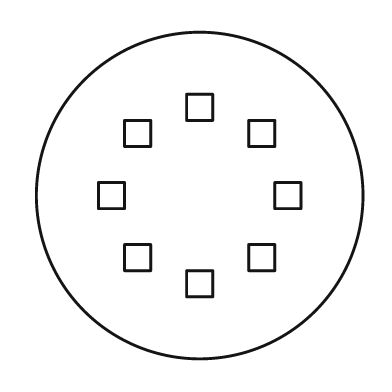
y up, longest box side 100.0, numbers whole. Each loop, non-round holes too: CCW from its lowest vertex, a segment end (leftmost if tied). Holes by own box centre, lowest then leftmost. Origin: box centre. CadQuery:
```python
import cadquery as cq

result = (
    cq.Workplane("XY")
    .moveTo(0.0, 0.0)
    .circle(50.0)
    .moveTo(-4.0, -31.0)
    .lineTo(4.0, -31.0)
    .lineTo(4.0, -23.0)
    .lineTo(-4.0, -23.0)
    .close()
    .moveTo(-23.0, -23.0)
    .lineTo(-15.0, -23.0)
    .lineTo(-15.0, -15.0)
    .lineTo(-23.0, -15.0)
    .close()
    .moveTo(15.0, -23.0)
    .lineTo(23.0, -23.0)
    .lineTo(23.0, -15.0)
    .lineTo(15.0, -15.0)
    .close()
    .moveTo(-31.0, -4.0)
    .lineTo(-23.0, -4.0)
    .lineTo(-23.0, 4.0)
    .lineTo(-31.0, 4.0)
    .close()
    .moveTo(23.0, -4.0)
    .lineTo(31.0, -4.0)
    .lineTo(31.0, 4.0)
    .lineTo(23.0, 4.0)
    .close()
    .moveTo(-23.0, 15.0)
    .lineTo(-15.0, 15.0)
    .lineTo(-15.0, 23.0)
    .lineTo(-23.0, 23.0)
    .close()
    .moveTo(15.0, 15.0)
    .lineTo(23.0, 15.0)
    .lineTo(23.0, 23.0)
    .lineTo(15.0, 23.0)
    .close()
    .moveTo(-4.0, 23.0)
    .lineTo(4.0, 23.0)
    .lineTo(4.0, 31.0)
    .lineTo(-4.0, 31.0)
    .close()
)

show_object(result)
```